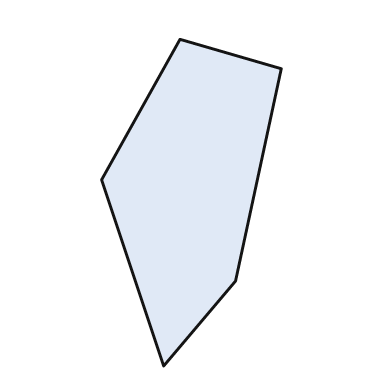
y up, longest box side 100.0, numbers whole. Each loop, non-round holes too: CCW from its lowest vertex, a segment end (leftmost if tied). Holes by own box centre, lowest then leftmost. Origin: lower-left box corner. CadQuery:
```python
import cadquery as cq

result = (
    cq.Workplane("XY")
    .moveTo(19.0, 0.0)
    .lineTo(41.0, 26.0)
    .lineTo(55.0, 91.0)
    .lineTo(24.0, 100.0)
    .lineTo(0.0, 57.0)
    .close()
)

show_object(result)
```